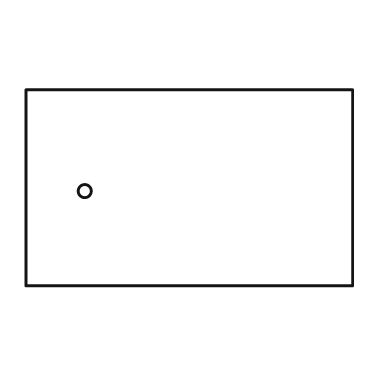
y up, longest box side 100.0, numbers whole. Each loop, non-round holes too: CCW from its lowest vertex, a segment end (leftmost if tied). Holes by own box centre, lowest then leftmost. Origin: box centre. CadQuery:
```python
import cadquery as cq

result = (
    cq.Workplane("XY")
    .moveTo(-50.0, -30.0)
    .lineTo(50.0, -30.0)
    .lineTo(50.0, 30.0)
    .lineTo(-50.0, 30.0)
    .close()
    .moveTo(-32.0, -1.0)
    .circle(2.0)
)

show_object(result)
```